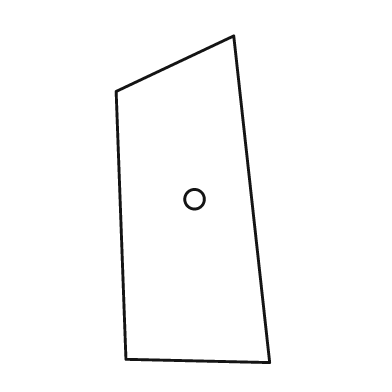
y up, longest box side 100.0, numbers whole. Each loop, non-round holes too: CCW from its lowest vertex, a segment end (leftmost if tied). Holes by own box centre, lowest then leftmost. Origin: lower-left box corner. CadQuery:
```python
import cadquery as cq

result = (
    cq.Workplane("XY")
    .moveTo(47.0, 0.0)
    .lineTo(36.0, 100.0)
    .lineTo(0.0, 83.0)
    .lineTo(3.0, 1.0)
    .close()
    .moveTo(24.0, 50.0)
    .circle(3.0)
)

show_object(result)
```